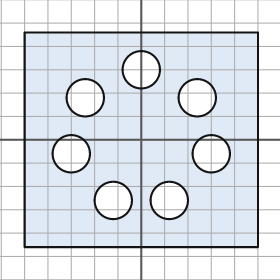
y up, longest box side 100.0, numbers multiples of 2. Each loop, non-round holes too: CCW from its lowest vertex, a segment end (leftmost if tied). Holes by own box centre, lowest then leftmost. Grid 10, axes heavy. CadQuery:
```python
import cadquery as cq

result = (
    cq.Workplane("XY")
    .moveTo(-50.0, -46.0)
    .lineTo(50.0, -46.0)
    .lineTo(50.0, 46.0)
    .lineTo(-50.0, 46.0)
    .close()
    .moveTo(-12.0, -26.0)
    .circle(8.0)
    .moveTo(12.0, -26.0)
    .circle(8.0)
    .moveTo(-30.0, -6.0)
    .circle(8.0)
    .moveTo(30.0, -6.0)
    .circle(8.0)
    .moveTo(-24.0, 18.0)
    .circle(8.0)
    .moveTo(24.0, 18.0)
    .circle(8.0)
    .moveTo(0.0, 30.0)
    .circle(8.0)
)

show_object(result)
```